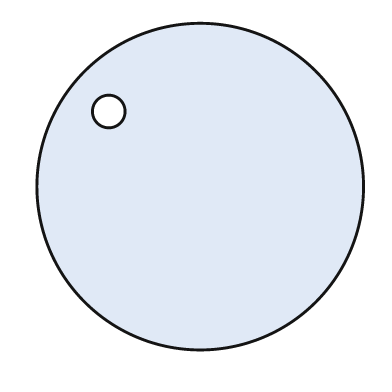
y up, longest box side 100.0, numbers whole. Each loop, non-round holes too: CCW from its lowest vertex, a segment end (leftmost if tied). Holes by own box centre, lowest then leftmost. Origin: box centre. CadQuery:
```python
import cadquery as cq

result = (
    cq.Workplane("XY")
    .moveTo(0.0, 0.0)
    .circle(50.0)
    .moveTo(-28.0, 23.0)
    .circle(5.0)
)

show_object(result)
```